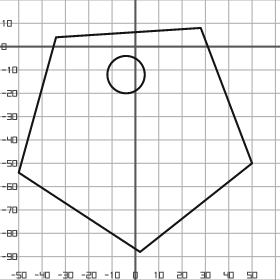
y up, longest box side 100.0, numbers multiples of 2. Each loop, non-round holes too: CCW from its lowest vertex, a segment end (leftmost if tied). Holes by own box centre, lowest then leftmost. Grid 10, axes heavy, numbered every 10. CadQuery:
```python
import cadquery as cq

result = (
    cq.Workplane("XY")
    .moveTo(2.0, -88.0)
    .lineTo(50.0, -50.0)
    .lineTo(28.0, 8.0)
    .lineTo(-34.0, 4.0)
    .lineTo(-50.0, -54.0)
    .close()
    .moveTo(-4.0, -12.0)
    .circle(8.0)
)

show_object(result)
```